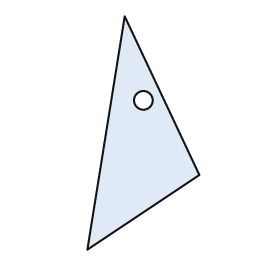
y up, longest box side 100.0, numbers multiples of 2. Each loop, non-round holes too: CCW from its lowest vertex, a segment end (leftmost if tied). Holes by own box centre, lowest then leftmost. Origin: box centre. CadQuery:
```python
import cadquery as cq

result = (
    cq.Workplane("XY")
    .moveTo(-24.0, -50.0)
    .lineTo(24.0, -18.0)
    .lineTo(-8.0, 50.0)
    .close()
    .moveTo(0.0, 14.0)
    .circle(4.0)
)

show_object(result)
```